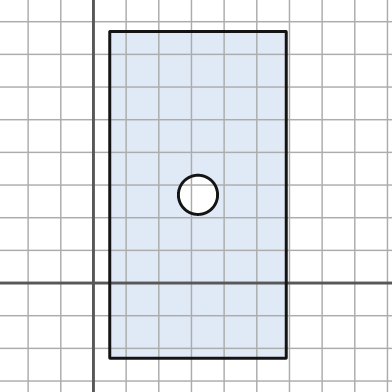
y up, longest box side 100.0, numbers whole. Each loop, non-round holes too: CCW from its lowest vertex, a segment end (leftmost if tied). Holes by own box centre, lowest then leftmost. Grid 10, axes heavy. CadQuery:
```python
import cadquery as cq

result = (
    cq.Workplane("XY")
    .moveTo(5.0, -23.0)
    .lineTo(59.0, -23.0)
    .lineTo(59.0, 77.0)
    .lineTo(5.0, 77.0)
    .close()
    .moveTo(32.0, 27.0)
    .circle(6.0)
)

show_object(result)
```